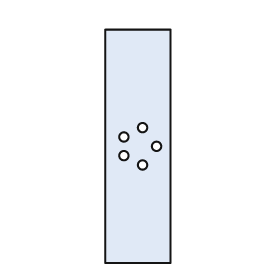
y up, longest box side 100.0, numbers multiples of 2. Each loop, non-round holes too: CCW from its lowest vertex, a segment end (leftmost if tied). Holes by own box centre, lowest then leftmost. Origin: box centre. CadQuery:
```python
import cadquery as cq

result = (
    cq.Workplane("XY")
    .moveTo(-14.0, -50.0)
    .lineTo(14.0, -50.0)
    .lineTo(14.0, 50.0)
    .lineTo(-14.0, 50.0)
    .close()
    .moveTo(2.0, -8.0)
    .circle(2.0)
    .moveTo(-6.0, -4.0)
    .circle(2.0)
    .moveTo(8.0, 0.0)
    .circle(2.0)
    .moveTo(-6.0, 4.0)
    .circle(2.0)
    .moveTo(2.0, 8.0)
    .circle(2.0)
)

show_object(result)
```